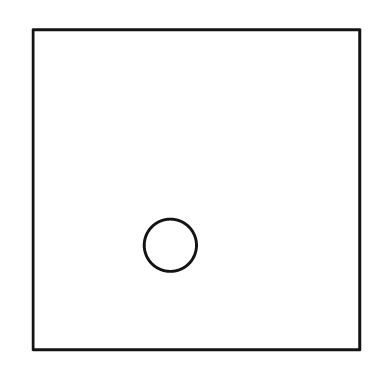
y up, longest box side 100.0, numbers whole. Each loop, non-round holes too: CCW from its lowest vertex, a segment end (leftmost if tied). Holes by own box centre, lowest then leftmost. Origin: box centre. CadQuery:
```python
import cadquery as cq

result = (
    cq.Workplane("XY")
    .moveTo(-50.0, -49.0)
    .lineTo(50.0, -49.0)
    .lineTo(50.0, 49.0)
    .lineTo(-50.0, 49.0)
    .close()
    .moveTo(-8.0, -17.0)
    .circle(8.0)
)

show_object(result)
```